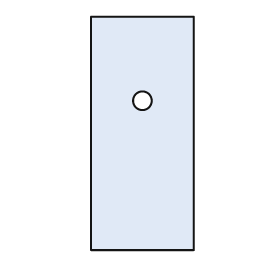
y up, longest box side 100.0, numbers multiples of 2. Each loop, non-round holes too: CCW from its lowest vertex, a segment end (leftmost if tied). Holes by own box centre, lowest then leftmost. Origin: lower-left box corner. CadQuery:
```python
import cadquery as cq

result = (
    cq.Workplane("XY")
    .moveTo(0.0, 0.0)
    .lineTo(44.0, 0.0)
    .lineTo(44.0, 100.0)
    .lineTo(0.0, 100.0)
    .close()
    .moveTo(22.0, 64.0)
    .circle(4.0)
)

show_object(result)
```